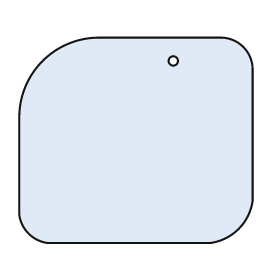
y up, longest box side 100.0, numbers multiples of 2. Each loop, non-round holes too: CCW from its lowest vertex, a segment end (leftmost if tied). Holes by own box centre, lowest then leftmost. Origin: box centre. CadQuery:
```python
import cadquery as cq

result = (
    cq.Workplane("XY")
    .moveTo(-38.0, -44.0)
    .lineTo(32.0, -44.0)
    .threePointArc((44.0, -38.0), (50.0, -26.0))
    .lineTo(50.0, 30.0)
    .threePointArc((46.0, 40.0), (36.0, 44.0))
    .lineTo(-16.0, 44.0)
    .threePointArc((-40.0, 34.0), (-50.0, 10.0))
    .lineTo(-50.0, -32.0)
    .threePointArc((-46.0, -40.0), (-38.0, -44.0))
    .close()
    .moveTo(16.0, 34.0)
    .circle(2.0)
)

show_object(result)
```